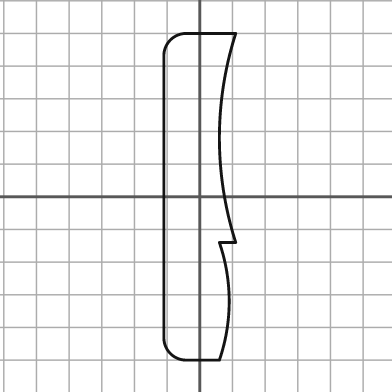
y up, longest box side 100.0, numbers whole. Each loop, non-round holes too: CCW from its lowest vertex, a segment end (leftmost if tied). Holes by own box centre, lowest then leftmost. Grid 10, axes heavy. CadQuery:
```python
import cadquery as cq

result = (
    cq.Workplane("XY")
    .moveTo(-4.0, -50.0)
    .lineTo(6.0, -50.0)
    .threePointArc((9.0, -32.0), (6.0, -14.0))
    .lineTo(11.0, -14.0)
    .threePointArc((6.0, 18.0), (11.0, 50.0))
    .lineTo(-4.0, 50.0)
    .threePointArc((-9.0, 48.0), (-11.0, 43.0))
    .lineTo(-11.0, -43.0)
    .threePointArc((-9.0, -48.0), (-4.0, -50.0))
    .close()
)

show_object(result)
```